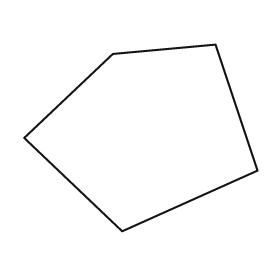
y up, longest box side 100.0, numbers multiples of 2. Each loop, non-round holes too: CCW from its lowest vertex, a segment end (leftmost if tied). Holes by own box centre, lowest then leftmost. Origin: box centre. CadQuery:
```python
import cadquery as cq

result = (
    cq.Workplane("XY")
    .moveTo(-8.0, -40.0)
    .lineTo(50.0, -14.0)
    .lineTo(32.0, 40.0)
    .lineTo(-12.0, 36.0)
    .lineTo(-50.0, 0.0)
    .close()
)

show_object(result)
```